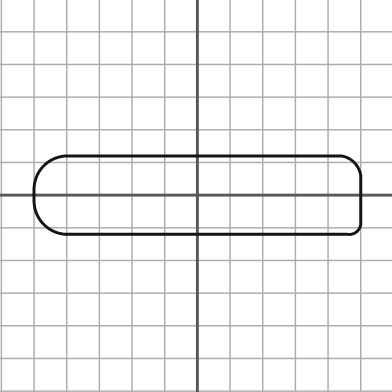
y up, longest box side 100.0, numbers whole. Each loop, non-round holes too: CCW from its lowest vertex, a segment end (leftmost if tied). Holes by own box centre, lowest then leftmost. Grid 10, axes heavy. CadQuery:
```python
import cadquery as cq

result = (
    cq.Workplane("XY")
    .moveTo(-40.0, -12.0)
    .lineTo(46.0, -12.0)
    .threePointArc((49.0, -11.0), (50.0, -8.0))
    .lineTo(50.0, 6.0)
    .threePointArc((48.0, 10.0), (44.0, 12.0))
    .lineTo(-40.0, 12.0)
    .threePointArc((-47.0, 9.0), (-50.0, 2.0))
    .lineTo(-50.0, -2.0)
    .threePointArc((-47.0, -9.0), (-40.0, -12.0))
    .close()
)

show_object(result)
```